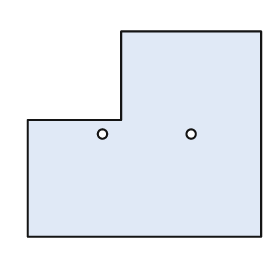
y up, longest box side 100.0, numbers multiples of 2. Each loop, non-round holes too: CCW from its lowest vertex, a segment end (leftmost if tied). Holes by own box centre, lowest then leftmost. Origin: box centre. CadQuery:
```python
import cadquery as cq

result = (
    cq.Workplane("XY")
    .moveTo(-50.0, -44.0)
    .lineTo(50.0, -44.0)
    .lineTo(50.0, 44.0)
    .lineTo(-10.0, 44.0)
    .lineTo(-10.0, 6.0)
    .lineTo(-50.0, 6.0)
    .close()
    .moveTo(-18.0, 0.0)
    .circle(2.0)
    .moveTo(20.0, 0.0)
    .circle(2.0)
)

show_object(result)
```